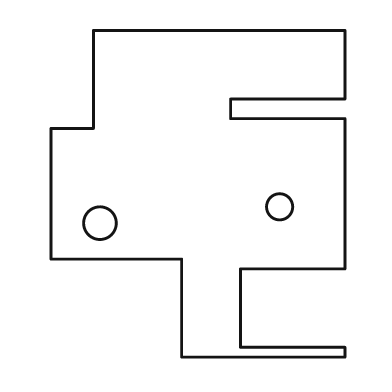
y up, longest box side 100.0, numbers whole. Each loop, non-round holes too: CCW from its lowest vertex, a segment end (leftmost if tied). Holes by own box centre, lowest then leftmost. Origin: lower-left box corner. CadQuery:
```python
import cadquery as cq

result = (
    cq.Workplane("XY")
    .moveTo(40.0, 0.0)
    .lineTo(90.0, 0.0)
    .lineTo(90.0, 3.0)
    .lineTo(58.0, 3.0)
    .lineTo(58.0, 27.0)
    .lineTo(90.0, 27.0)
    .lineTo(90.0, 73.0)
    .lineTo(55.0, 73.0)
    .lineTo(55.0, 79.0)
    .lineTo(90.0, 79.0)
    .lineTo(90.0, 100.0)
    .lineTo(13.0, 100.0)
    .lineTo(13.0, 70.0)
    .lineTo(0.0, 70.0)
    .lineTo(0.0, 30.0)
    .lineTo(40.0, 30.0)
    .close()
    .moveTo(15.0, 41.0)
    .circle(5.0)
    .moveTo(70.0, 46.0)
    .circle(4.0)
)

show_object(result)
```